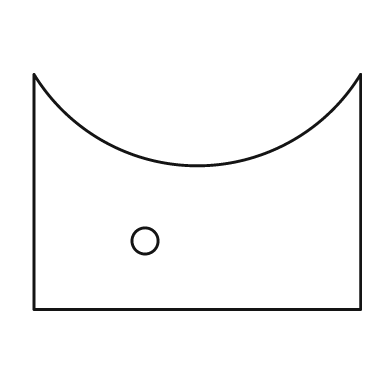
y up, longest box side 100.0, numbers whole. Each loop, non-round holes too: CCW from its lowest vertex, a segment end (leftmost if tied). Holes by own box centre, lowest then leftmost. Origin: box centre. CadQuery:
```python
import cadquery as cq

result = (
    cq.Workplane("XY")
    .moveTo(-50.0, -36.0)
    .lineTo(50.0, -36.0)
    .lineTo(50.0, 36.0)
    .threePointArc((0.0, 8.0), (-50.0, 36.0))
    .close()
    .moveTo(-16.0, -15.0)
    .circle(4.0)
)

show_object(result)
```